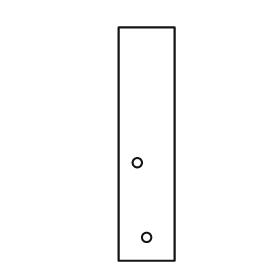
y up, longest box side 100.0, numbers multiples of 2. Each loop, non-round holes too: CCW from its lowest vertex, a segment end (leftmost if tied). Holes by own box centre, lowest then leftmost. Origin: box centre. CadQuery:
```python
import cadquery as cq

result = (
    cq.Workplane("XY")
    .moveTo(-12.0, -50.0)
    .lineTo(12.0, -50.0)
    .lineTo(12.0, 50.0)
    .lineTo(-12.0, 50.0)
    .close()
    .moveTo(0.0, -40.0)
    .circle(2.0)
    .moveTo(-4.0, -8.0)
    .circle(2.0)
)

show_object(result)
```